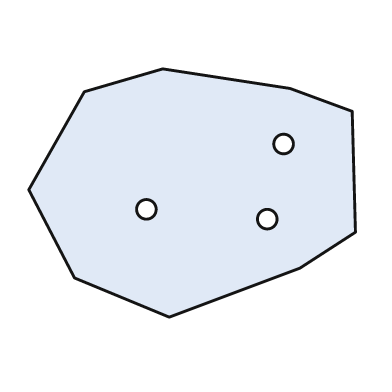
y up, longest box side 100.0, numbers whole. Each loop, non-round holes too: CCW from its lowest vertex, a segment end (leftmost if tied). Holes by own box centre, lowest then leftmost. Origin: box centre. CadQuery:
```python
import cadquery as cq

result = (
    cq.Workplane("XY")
    .moveTo(-7.0, -38.0)
    .lineTo(33.0, -23.0)
    .lineTo(50.0, -12.0)
    .lineTo(49.0, 25.0)
    .lineTo(30.0, 32.0)
    .lineTo(-9.0, 38.0)
    .lineTo(-33.0, 31.0)
    .lineTo(-50.0, 1.0)
    .lineTo(-36.0, -26.0)
    .close()
    .moveTo(23.0, -8.0)
    .circle(3.0)
    .moveTo(-14.0, -5.0)
    .circle(3.0)
    .moveTo(28.0, 15.0)
    .circle(3.0)
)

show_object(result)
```